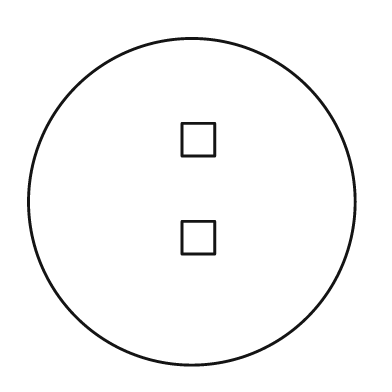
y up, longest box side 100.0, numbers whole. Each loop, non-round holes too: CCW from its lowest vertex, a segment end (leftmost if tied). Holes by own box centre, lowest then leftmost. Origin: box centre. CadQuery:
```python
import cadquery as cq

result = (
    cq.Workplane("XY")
    .moveTo(0.0, 0.0)
    .circle(50.0)
    .moveTo(-3.0, -16.0)
    .lineTo(7.0, -16.0)
    .lineTo(7.0, -6.0)
    .lineTo(-3.0, -6.0)
    .close()
    .moveTo(-3.0, 14.0)
    .lineTo(7.0, 14.0)
    .lineTo(7.0, 24.0)
    .lineTo(-3.0, 24.0)
    .close()
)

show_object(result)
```